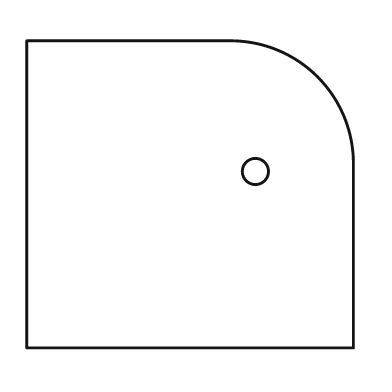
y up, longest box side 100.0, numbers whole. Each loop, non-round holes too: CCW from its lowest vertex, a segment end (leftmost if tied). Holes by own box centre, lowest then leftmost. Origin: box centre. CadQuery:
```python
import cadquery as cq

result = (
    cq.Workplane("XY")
    .moveTo(-50.0, -47.0)
    .lineTo(50.0, -47.0)
    .lineTo(50.0, 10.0)
    .threePointArc((39.0, 36.0), (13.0, 47.0))
    .lineTo(-50.0, 47.0)
    .close()
    .moveTo(20.0, 7.0)
    .circle(4.0)
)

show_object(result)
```